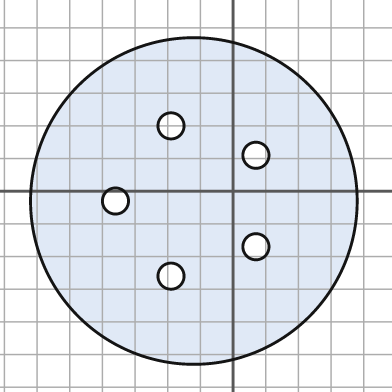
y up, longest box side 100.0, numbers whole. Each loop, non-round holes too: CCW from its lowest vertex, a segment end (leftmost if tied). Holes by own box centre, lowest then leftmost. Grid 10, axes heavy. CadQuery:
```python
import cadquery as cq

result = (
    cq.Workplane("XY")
    .moveTo(-12.0, -3.0)
    .circle(50.0)
    .moveTo(-19.0, -26.0)
    .circle(4.0)
    .moveTo(7.0, -17.0)
    .circle(4.0)
    .moveTo(-36.0, -3.0)
    .circle(4.0)
    .moveTo(7.0, 11.0)
    .circle(4.0)
    .moveTo(-19.0, 20.0)
    .circle(4.0)
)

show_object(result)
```